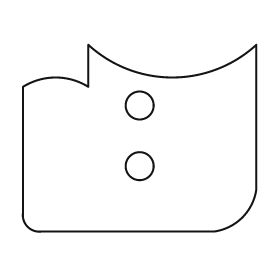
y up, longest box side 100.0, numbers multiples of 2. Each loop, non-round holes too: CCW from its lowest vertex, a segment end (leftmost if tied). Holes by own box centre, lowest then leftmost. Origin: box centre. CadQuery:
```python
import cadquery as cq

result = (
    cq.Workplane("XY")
    .moveTo(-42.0, -40.0)
    .lineTo(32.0, -40.0)
    .threePointArc((44.0, -34.0), (50.0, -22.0))
    .lineTo(50.0, 40.0)
    .threePointArc((14.0, 26.0), (-22.0, 40.0))
    .lineTo(-22.0, 22.0)
    .threePointArc((-36.0, 26.0), (-50.0, 22.0))
    .lineTo(-50.0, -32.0)
    .threePointArc((-48.0, -38.0), (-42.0, -40.0))
    .close()
    .moveTo(0.0, -12.0)
    .circle(6.0)
    .moveTo(0.0, 14.0)
    .circle(6.0)
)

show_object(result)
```